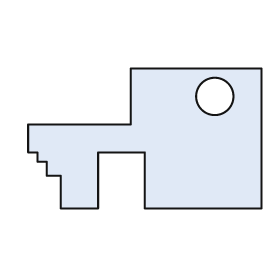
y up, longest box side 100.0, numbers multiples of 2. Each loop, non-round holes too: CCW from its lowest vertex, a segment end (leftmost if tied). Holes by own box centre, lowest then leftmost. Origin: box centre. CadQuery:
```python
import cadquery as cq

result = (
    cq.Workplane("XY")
    .moveTo(-36.0, -30.0)
    .lineTo(-20.0, -30.0)
    .lineTo(-20.0, -6.0)
    .lineTo(0.0, -6.0)
    .lineTo(0.0, -30.0)
    .lineTo(50.0, -30.0)
    .lineTo(50.0, 30.0)
    .lineTo(-6.0, 30.0)
    .lineTo(-6.0, 6.0)
    .lineTo(-50.0, 6.0)
    .lineTo(-50.0, -6.0)
    .lineTo(-46.0, -6.0)
    .lineTo(-46.0, -10.0)
    .lineTo(-42.0, -10.0)
    .lineTo(-42.0, -16.0)
    .lineTo(-36.0, -16.0)
    .close()
    .moveTo(30.0, 18.0)
    .circle(8.0)
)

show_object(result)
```